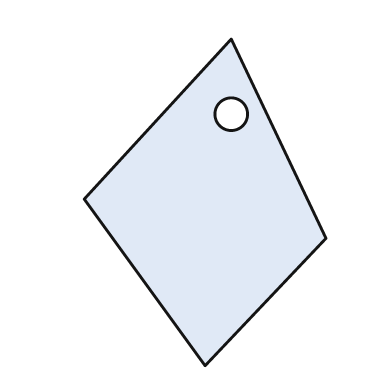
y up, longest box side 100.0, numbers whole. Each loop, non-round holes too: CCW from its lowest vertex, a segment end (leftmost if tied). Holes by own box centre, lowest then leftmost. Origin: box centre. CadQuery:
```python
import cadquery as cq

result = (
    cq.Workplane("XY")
    .moveTo(0.0, -50.0)
    .lineTo(37.0, -11.0)
    .lineTo(8.0, 50.0)
    .lineTo(-37.0, 1.0)
    .close()
    .moveTo(8.0, 27.0)
    .circle(5.0)
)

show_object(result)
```